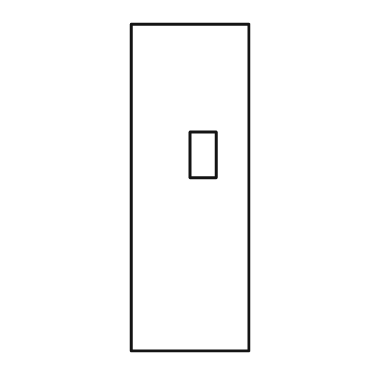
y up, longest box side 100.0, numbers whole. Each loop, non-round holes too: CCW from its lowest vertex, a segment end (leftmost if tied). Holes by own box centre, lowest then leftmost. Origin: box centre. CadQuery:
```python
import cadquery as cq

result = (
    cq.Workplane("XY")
    .moveTo(-18.0, -50.0)
    .lineTo(18.0, -50.0)
    .lineTo(18.0, 50.0)
    .lineTo(-18.0, 50.0)
    .close()
    .moveTo(0.0, 3.0)
    .lineTo(8.0, 3.0)
    .lineTo(8.0, 17.0)
    .lineTo(0.0, 17.0)
    .close()
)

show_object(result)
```